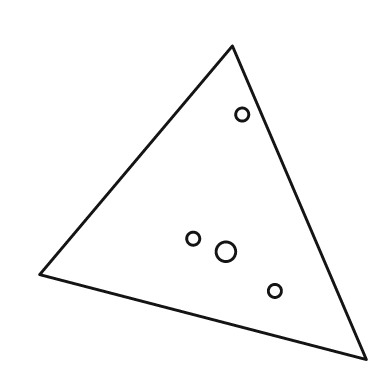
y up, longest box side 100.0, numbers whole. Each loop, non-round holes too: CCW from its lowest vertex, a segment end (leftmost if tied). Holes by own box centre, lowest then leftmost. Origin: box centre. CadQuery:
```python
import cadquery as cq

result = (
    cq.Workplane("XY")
    .moveTo(50.0, -48.0)
    .lineTo(9.0, 48.0)
    .lineTo(-50.0, -22.0)
    .close()
    .moveTo(22.0, -27.0)
    .circle(2.0)
    .moveTo(7.0, -15.0)
    .circle(3.0)
    .moveTo(-3.0, -11.0)
    .circle(2.0)
    .moveTo(12.0, 27.0)
    .circle(2.0)
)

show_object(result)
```